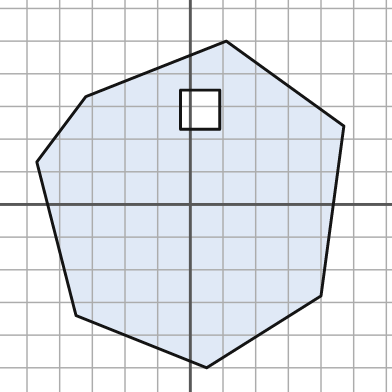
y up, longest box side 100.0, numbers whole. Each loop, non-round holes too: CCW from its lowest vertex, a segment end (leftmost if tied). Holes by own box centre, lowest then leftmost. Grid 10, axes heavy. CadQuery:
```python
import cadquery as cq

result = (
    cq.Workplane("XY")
    .moveTo(5.0, -50.0)
    .lineTo(40.0, -28.0)
    .lineTo(47.0, 24.0)
    .lineTo(11.0, 50.0)
    .lineTo(-32.0, 33.0)
    .lineTo(-47.0, 13.0)
    .lineTo(-35.0, -34.0)
    .close()
    .moveTo(-3.0, 23.0)
    .lineTo(9.0, 23.0)
    .lineTo(9.0, 35.0)
    .lineTo(-3.0, 35.0)
    .close()
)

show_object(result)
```